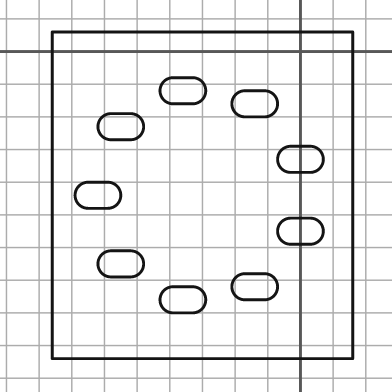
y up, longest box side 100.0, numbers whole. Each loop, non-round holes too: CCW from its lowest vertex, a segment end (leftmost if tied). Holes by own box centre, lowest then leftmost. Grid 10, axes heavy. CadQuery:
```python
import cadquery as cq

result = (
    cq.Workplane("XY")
    .moveTo(-76.0, -94.0)
    .lineTo(16.0, -94.0)
    .lineTo(16.0, 6.0)
    .lineTo(-76.0, 6.0)
    .close()
    .moveTo(-39.0, -80.0)
    .lineTo(-33.0, -80.0)
    .threePointArc((-29.0, -76.0), (-33.0, -72.0))
    .lineTo(-39.0, -72.0)
    .threePointArc((-43.0, -76.0), (-39.0, -80.0))
    .close()
    .moveTo(-17.0, -76.0)
    .lineTo(-11.0, -76.0)
    .threePointArc((-7.0, -72.0), (-11.0, -68.0))
    .lineTo(-17.0, -68.0)
    .threePointArc((-21.0, -72.0), (-17.0, -76.0))
    .close()
    .moveTo(-58.0, -69.0)
    .lineTo(-52.0, -69.0)
    .threePointArc((-48.0, -65.0), (-52.0, -61.0))
    .lineTo(-58.0, -61.0)
    .threePointArc((-62.0, -65.0), (-58.0, -69.0))
    .close()
    .moveTo(-3.0, -59.0)
    .lineTo(3.0, -59.0)
    .threePointArc((7.0, -55.0), (3.0, -51.0))
    .lineTo(-3.0, -51.0)
    .threePointArc((-7.0, -55.0), (-3.0, -59.0))
    .close()
    .moveTo(-65.0, -48.0)
    .lineTo(-59.0, -48.0)
    .threePointArc((-55.0, -44.0), (-59.0, -40.0))
    .lineTo(-65.0, -40.0)
    .threePointArc((-69.0, -44.0), (-65.0, -48.0))
    .close()
    .moveTo(-3.0, -37.0)
    .lineTo(3.0, -37.0)
    .threePointArc((7.0, -33.0), (3.0, -29.0))
    .lineTo(-3.0, -29.0)
    .threePointArc((-7.0, -33.0), (-3.0, -37.0))
    .close()
    .moveTo(-58.0, -27.0)
    .lineTo(-52.0, -27.0)
    .threePointArc((-48.0, -23.0), (-52.0, -19.0))
    .lineTo(-58.0, -19.0)
    .threePointArc((-62.0, -23.0), (-58.0, -27.0))
    .close()
    .moveTo(-17.0, -20.0)
    .lineTo(-11.0, -20.0)
    .threePointArc((-7.0, -16.0), (-11.0, -12.0))
    .lineTo(-17.0, -12.0)
    .threePointArc((-21.0, -16.0), (-17.0, -20.0))
    .close()
    .moveTo(-39.0, -16.0)
    .lineTo(-33.0, -16.0)
    .threePointArc((-29.0, -12.0), (-33.0, -8.0))
    .lineTo(-39.0, -8.0)
    .threePointArc((-43.0, -12.0), (-39.0, -16.0))
    .close()
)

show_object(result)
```